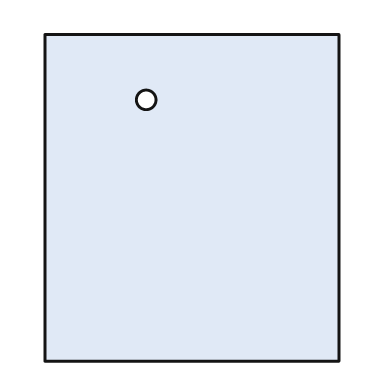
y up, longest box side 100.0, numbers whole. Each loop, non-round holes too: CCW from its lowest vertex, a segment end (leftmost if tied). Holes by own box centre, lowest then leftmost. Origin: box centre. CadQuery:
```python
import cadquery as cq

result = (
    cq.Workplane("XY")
    .moveTo(-45.0, -50.0)
    .lineTo(45.0, -50.0)
    .lineTo(45.0, 50.0)
    .lineTo(-45.0, 50.0)
    .close()
    .moveTo(-14.0, 30.0)
    .circle(3.0)
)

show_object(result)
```